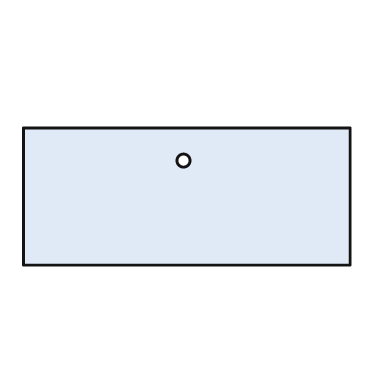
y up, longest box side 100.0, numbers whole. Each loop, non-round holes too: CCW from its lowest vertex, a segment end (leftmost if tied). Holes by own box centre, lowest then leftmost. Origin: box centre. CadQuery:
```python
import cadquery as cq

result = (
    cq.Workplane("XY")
    .moveTo(-50.0, -21.0)
    .lineTo(50.0, -21.0)
    .lineTo(50.0, 21.0)
    .lineTo(-50.0, 21.0)
    .close()
    .moveTo(-1.0, 11.0)
    .circle(2.0)
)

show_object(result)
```